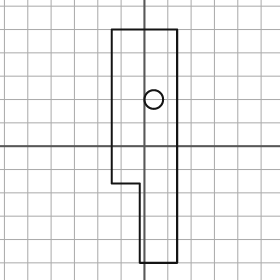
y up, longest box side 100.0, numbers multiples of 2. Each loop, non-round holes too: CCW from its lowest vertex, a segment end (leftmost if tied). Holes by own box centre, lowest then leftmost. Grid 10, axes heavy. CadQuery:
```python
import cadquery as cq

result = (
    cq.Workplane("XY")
    .moveTo(-2.0, -50.0)
    .lineTo(14.0, -50.0)
    .lineTo(14.0, 50.0)
    .lineTo(-14.0, 50.0)
    .lineTo(-14.0, -16.0)
    .lineTo(-2.0, -16.0)
    .close()
    .moveTo(4.0, 20.0)
    .circle(4.0)
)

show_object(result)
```